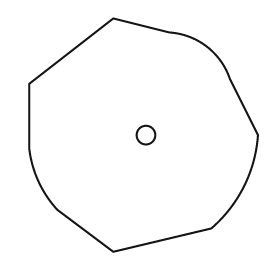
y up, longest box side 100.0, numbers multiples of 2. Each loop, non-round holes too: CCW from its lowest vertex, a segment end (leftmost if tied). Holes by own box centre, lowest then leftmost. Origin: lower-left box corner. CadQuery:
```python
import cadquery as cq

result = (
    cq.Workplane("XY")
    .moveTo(36.0, 0.0)
    .lineTo(78.0, 10.0)
    .threePointArc((92.0, 28.0), (98.0, 50.0))
    .lineTo(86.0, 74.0)
    .threePointArc((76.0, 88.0), (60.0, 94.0))
    .lineTo(36.0, 100.0)
    .lineTo(0.0, 72.0)
    .lineTo(0.0, 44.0)
    .threePointArc((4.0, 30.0), (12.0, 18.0))
    .close()
    .moveTo(50.0, 50.0)
    .circle(4.0)
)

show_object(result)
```